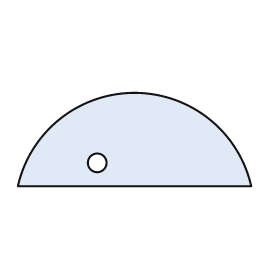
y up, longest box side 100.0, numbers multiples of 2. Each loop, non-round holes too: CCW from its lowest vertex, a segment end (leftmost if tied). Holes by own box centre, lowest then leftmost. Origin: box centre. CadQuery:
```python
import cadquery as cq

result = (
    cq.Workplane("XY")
    .moveTo(-50.0, -20.0)
    .lineTo(50.0, -20.0)
    .threePointArc((0.0, 20.0), (-50.0, -20.0))
    .close()
    .moveTo(-16.0, -10.0)
    .circle(4.0)
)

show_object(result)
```